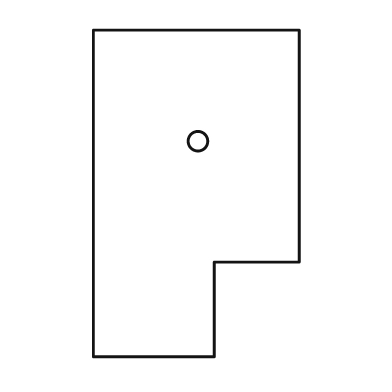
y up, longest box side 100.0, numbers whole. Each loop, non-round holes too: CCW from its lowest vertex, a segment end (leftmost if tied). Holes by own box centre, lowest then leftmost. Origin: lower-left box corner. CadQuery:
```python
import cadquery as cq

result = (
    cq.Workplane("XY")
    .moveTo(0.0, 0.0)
    .lineTo(37.0, 0.0)
    .lineTo(37.0, 29.0)
    .lineTo(63.0, 29.0)
    .lineTo(63.0, 100.0)
    .lineTo(0.0, 100.0)
    .close()
    .moveTo(32.0, 66.0)
    .circle(3.0)
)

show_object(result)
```